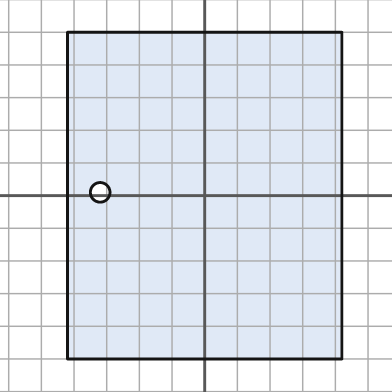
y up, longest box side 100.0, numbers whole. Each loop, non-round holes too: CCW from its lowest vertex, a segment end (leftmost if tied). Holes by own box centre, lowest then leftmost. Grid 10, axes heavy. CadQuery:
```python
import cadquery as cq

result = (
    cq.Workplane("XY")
    .moveTo(-42.0, -50.0)
    .lineTo(42.0, -50.0)
    .lineTo(42.0, 50.0)
    .lineTo(-42.0, 50.0)
    .close()
    .moveTo(-32.0, 1.0)
    .circle(3.0)
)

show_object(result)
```